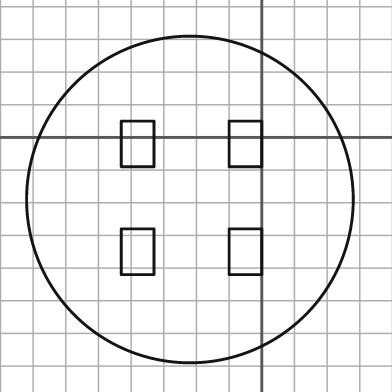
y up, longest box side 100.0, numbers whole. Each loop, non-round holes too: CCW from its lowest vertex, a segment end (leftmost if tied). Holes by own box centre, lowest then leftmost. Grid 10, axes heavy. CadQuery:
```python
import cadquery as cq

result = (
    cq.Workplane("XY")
    .moveTo(-22.0, -19.0)
    .circle(50.0)
    .moveTo(-43.0, -42.0)
    .lineTo(-33.0, -42.0)
    .lineTo(-33.0, -28.0)
    .lineTo(-43.0, -28.0)
    .close()
    .moveTo(-10.0, -42.0)
    .lineTo(0.0, -42.0)
    .lineTo(0.0, -28.0)
    .lineTo(-10.0, -28.0)
    .close()
    .moveTo(-43.0, -9.0)
    .lineTo(-33.0, -9.0)
    .lineTo(-33.0, 5.0)
    .lineTo(-43.0, 5.0)
    .close()
    .moveTo(-10.0, -9.0)
    .lineTo(0.0, -9.0)
    .lineTo(0.0, 5.0)
    .lineTo(-10.0, 5.0)
    .close()
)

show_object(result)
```